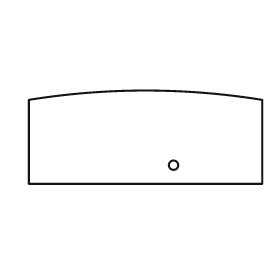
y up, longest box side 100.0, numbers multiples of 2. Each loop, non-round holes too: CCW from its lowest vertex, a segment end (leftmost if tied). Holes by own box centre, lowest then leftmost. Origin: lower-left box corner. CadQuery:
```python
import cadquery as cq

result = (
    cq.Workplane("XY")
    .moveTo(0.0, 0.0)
    .lineTo(100.0, 0.0)
    .lineTo(100.0, 36.0)
    .threePointArc((50.0, 40.0), (0.0, 36.0))
    .close()
    .moveTo(62.0, 8.0)
    .circle(2.0)
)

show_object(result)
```